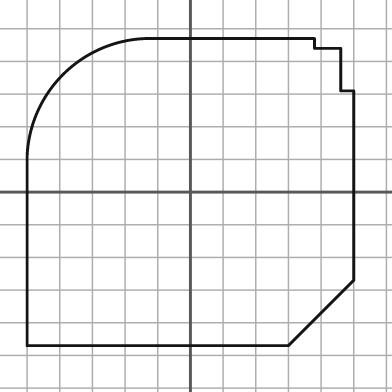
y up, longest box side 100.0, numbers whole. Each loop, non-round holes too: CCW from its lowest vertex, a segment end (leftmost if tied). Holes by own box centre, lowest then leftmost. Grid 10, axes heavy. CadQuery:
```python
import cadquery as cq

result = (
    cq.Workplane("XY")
    .moveTo(-50.0, -47.0)
    .lineTo(30.0, -47.0)
    .lineTo(50.0, -27.0)
    .lineTo(50.0, 31.0)
    .lineTo(46.0, 31.0)
    .lineTo(46.0, 44.0)
    .lineTo(38.0, 44.0)
    .lineTo(38.0, 47.0)
    .lineTo(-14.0, 47.0)
    .threePointArc((-39.0, 36.0), (-50.0, 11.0))
    .close()
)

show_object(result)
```